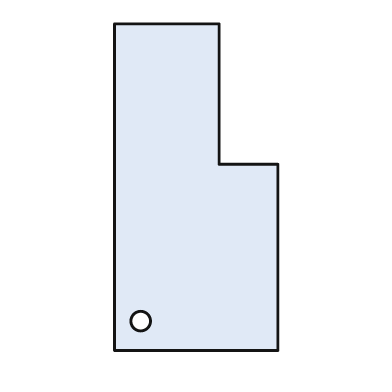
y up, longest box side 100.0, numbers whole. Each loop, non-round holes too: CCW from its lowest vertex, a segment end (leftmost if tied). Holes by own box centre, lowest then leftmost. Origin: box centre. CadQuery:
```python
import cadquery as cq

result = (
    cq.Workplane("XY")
    .moveTo(-25.0, -50.0)
    .lineTo(25.0, -50.0)
    .lineTo(25.0, 7.0)
    .lineTo(7.0, 7.0)
    .lineTo(7.0, 50.0)
    .lineTo(-25.0, 50.0)
    .close()
    .moveTo(-17.0, -41.0)
    .circle(3.0)
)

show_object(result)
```